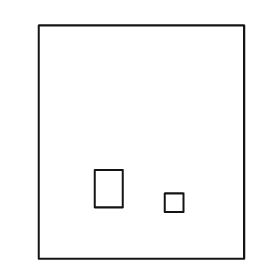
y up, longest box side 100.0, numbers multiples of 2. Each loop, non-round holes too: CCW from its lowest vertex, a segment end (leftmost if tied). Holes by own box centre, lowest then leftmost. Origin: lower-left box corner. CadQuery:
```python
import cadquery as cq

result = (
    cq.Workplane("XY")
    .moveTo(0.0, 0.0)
    .lineTo(88.0, 0.0)
    .lineTo(88.0, 100.0)
    .lineTo(0.0, 100.0)
    .close()
    .moveTo(54.0, 20.0)
    .lineTo(62.0, 20.0)
    .lineTo(62.0, 28.0)
    .lineTo(54.0, 28.0)
    .close()
    .moveTo(24.0, 22.0)
    .lineTo(36.0, 22.0)
    .lineTo(36.0, 38.0)
    .lineTo(24.0, 38.0)
    .close()
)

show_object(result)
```